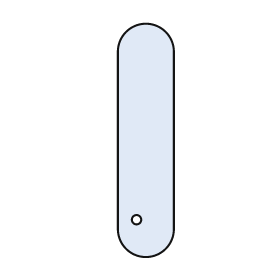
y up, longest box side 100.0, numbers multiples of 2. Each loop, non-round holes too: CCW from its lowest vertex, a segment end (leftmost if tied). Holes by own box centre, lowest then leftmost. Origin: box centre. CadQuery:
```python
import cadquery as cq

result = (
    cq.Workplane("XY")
    .moveTo(-12.0, -38.0)
    .threePointArc((0.0, -50.0), (12.0, -38.0))
    .lineTo(12.0, 38.0)
    .threePointArc((0.0, 50.0), (-12.0, 38.0))
    .close()
    .moveTo(-4.0, -34.0)
    .circle(2.0)
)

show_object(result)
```